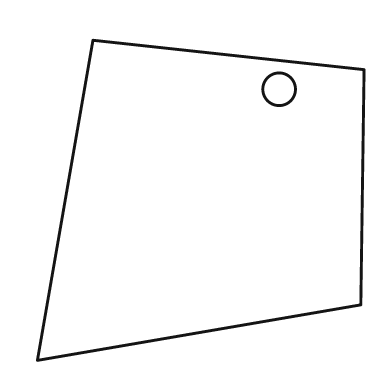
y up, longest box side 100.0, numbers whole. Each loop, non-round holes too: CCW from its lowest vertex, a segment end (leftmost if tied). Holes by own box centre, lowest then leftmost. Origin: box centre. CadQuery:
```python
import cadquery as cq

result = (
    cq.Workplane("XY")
    .moveTo(-50.0, -49.0)
    .lineTo(49.0, -32.0)
    .lineTo(50.0, 40.0)
    .lineTo(-33.0, 49.0)
    .close()
    .moveTo(24.0, 34.0)
    .circle(5.0)
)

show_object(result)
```